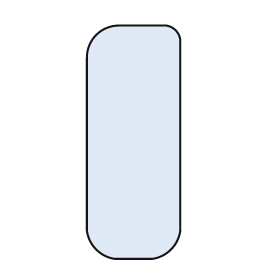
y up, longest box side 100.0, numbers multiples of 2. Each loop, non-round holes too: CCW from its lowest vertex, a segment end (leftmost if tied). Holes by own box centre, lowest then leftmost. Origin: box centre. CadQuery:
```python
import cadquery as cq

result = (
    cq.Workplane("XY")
    .moveTo(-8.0, -50.0)
    .lineTo(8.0, -50.0)
    .threePointArc((16.0, -46.0), (20.0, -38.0))
    .lineTo(20.0, 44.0)
    .threePointArc((18.0, 48.0), (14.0, 50.0))
    .lineTo(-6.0, 50.0)
    .threePointArc((-16.0, 46.0), (-20.0, 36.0))
    .lineTo(-20.0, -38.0)
    .threePointArc((-16.0, -46.0), (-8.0, -50.0))
    .close()
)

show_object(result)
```